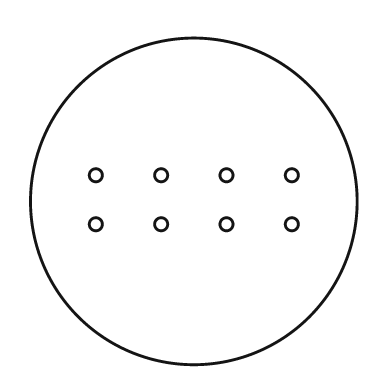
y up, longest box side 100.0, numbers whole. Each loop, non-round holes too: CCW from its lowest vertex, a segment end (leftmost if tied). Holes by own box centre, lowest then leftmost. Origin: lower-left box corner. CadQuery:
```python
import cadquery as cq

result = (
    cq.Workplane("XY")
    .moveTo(50.0, 50.0)
    .circle(50.0)
    .moveTo(20.0, 43.0)
    .circle(2.0)
    .moveTo(40.0, 43.0)
    .circle(2.0)
    .moveTo(60.0, 43.0)
    .circle(2.0)
    .moveTo(80.0, 43.0)
    .circle(2.0)
    .moveTo(20.0, 58.0)
    .circle(2.0)
    .moveTo(40.0, 58.0)
    .circle(2.0)
    .moveTo(60.0, 58.0)
    .circle(2.0)
    .moveTo(80.0, 58.0)
    .circle(2.0)
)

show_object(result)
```